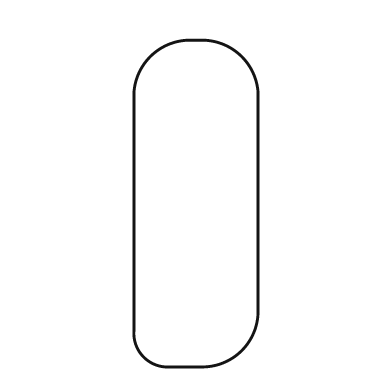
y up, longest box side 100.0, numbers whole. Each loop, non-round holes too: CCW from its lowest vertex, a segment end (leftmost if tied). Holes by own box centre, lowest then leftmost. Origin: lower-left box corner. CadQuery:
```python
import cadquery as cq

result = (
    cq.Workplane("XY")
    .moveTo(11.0, 0.0)
    .lineTo(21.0, 0.0)
    .threePointArc((33.0, 5.0), (38.0, 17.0))
    .lineTo(38.0, 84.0)
    .threePointArc((33.0, 95.0), (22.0, 100.0))
    .lineTo(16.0, 100.0)
    .threePointArc((5.0, 95.0), (0.0, 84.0))
    .lineTo(0.0, 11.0)
    .threePointArc((3.0, 3.0), (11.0, 0.0))
    .close()
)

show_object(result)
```